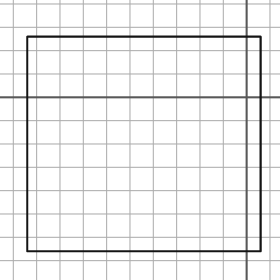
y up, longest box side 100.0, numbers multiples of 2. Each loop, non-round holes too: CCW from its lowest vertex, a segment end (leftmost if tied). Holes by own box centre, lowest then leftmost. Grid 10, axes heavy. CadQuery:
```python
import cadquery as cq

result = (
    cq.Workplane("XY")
    .moveTo(-94.0, -66.0)
    .lineTo(6.0, -66.0)
    .lineTo(6.0, 26.0)
    .lineTo(-94.0, 26.0)
    .close()
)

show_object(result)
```